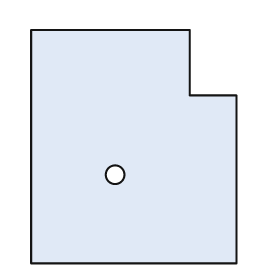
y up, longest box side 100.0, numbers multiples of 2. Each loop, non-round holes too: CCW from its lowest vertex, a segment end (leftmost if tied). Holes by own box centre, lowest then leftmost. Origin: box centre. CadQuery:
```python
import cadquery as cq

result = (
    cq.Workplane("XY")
    .moveTo(-44.0, -50.0)
    .lineTo(44.0, -50.0)
    .lineTo(44.0, 22.0)
    .lineTo(24.0, 22.0)
    .lineTo(24.0, 50.0)
    .lineTo(-44.0, 50.0)
    .close()
    .moveTo(-8.0, -12.0)
    .circle(4.0)
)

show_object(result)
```